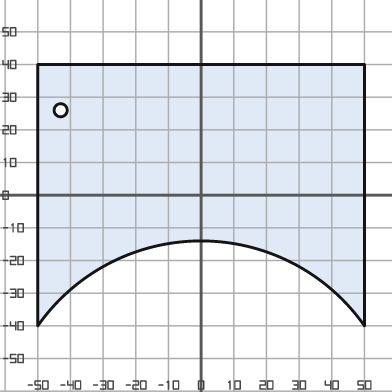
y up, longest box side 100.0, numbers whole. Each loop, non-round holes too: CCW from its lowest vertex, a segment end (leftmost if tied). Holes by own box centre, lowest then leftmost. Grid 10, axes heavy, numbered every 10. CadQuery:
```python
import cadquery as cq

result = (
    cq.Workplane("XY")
    .moveTo(-50.0, -40.0)
    .threePointArc((0.0, -14.0), (50.0, -40.0))
    .lineTo(50.0, 40.0)
    .lineTo(-50.0, 40.0)
    .close()
    .moveTo(-43.0, 26.0)
    .circle(2.0)
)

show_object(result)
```